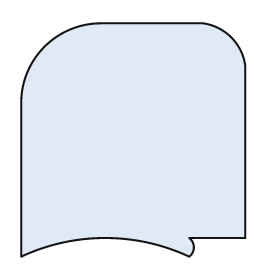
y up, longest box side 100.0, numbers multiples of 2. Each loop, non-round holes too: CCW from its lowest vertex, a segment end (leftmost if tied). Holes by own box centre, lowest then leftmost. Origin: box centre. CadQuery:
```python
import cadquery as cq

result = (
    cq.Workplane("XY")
    .moveTo(-48.0, -50.0)
    .threePointArc((-12.0, -42.0), (24.0, -50.0))
    .threePointArc((26.0, -46.0), (24.0, -42.0))
    .lineTo(48.0, -42.0)
    .lineTo(48.0, 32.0)
    .threePointArc((42.0, 44.0), (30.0, 50.0))
    .lineTo(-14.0, 50.0)
    .threePointArc((-38.0, 40.0), (-48.0, 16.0))
    .close()
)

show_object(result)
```